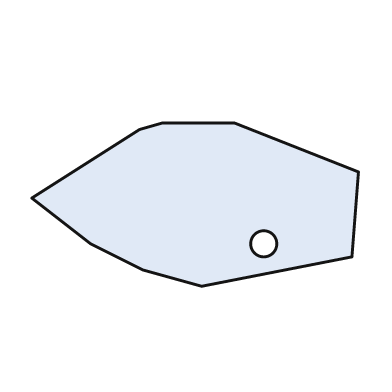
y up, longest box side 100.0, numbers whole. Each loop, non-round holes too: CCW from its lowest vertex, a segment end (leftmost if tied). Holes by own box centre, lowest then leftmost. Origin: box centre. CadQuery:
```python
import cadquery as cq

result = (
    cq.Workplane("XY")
    .moveTo(2.0, -25.0)
    .lineTo(48.0, -16.0)
    .lineTo(50.0, 10.0)
    .lineTo(12.0, 25.0)
    .lineTo(-10.0, 25.0)
    .lineTo(-17.0, 23.0)
    .lineTo(-50.0, 2.0)
    .lineTo(-32.0, -12.0)
    .lineTo(-16.0, -20.0)
    .close()
    .moveTo(21.0, -12.0)
    .circle(4.0)
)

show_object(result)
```